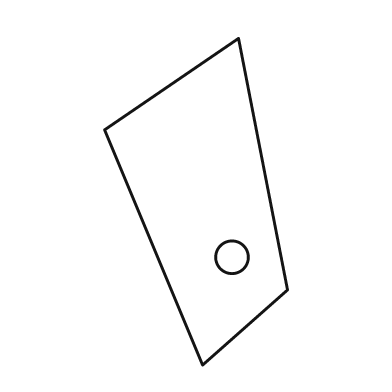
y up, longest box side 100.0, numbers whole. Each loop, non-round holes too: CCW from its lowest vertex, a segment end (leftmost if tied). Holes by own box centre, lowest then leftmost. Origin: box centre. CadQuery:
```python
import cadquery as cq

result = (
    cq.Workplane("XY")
    .moveTo(2.0, -50.0)
    .lineTo(28.0, -27.0)
    .lineTo(13.0, 50.0)
    .lineTo(-28.0, 22.0)
    .close()
    .moveTo(11.0, -17.0)
    .circle(5.0)
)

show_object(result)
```